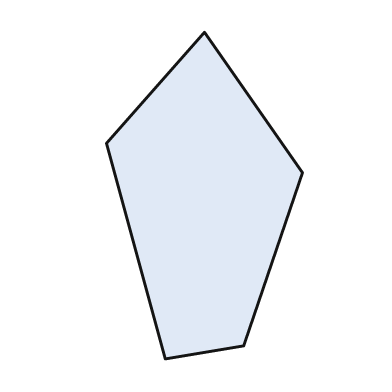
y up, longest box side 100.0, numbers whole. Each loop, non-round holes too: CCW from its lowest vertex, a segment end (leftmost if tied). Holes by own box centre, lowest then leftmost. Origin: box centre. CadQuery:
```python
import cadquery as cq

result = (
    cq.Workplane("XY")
    .moveTo(-12.0, -50.0)
    .lineTo(12.0, -46.0)
    .lineTo(30.0, 7.0)
    .lineTo(0.0, 50.0)
    .lineTo(-30.0, 16.0)
    .close()
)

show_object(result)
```